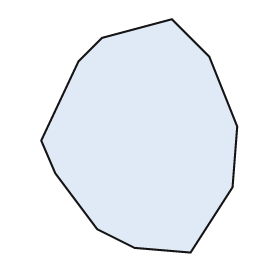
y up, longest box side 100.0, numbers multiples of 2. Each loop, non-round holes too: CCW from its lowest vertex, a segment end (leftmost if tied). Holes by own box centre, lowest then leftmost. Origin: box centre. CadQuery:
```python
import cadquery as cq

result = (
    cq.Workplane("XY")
    .moveTo(22.0, -50.0)
    .lineTo(40.0, -22.0)
    .lineTo(42.0, 4.0)
    .lineTo(30.0, 34.0)
    .lineTo(14.0, 50.0)
    .lineTo(-16.0, 42.0)
    .lineTo(-26.0, 32.0)
    .lineTo(-42.0, -2.0)
    .lineTo(-36.0, -16.0)
    .lineTo(-18.0, -40.0)
    .lineTo(-2.0, -48.0)
    .close()
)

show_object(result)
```